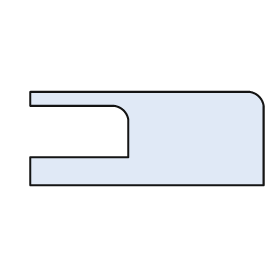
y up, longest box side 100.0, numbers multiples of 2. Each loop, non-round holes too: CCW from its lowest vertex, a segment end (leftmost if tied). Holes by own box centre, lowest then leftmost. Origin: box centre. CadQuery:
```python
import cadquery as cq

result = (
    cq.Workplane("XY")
    .moveTo(-50.0, -20.0)
    .lineTo(50.0, -20.0)
    .lineTo(50.0, 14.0)
    .threePointArc((48.0, 18.0), (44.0, 20.0))
    .lineTo(-50.0, 20.0)
    .lineTo(-50.0, 14.0)
    .lineTo(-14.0, 14.0)
    .threePointArc((-10.0, 12.0), (-8.0, 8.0))
    .lineTo(-8.0, -8.0)
    .lineTo(-50.0, -8.0)
    .close()
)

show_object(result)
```